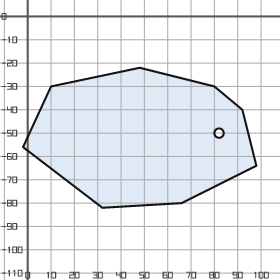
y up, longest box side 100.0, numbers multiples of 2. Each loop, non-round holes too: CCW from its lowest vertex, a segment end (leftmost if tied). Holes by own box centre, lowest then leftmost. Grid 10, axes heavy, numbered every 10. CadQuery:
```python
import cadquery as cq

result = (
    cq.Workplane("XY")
    .moveTo(32.0, -82.0)
    .lineTo(66.0, -80.0)
    .lineTo(98.0, -64.0)
    .lineTo(92.0, -40.0)
    .lineTo(80.0, -30.0)
    .lineTo(48.0, -22.0)
    .lineTo(10.0, -30.0)
    .lineTo(-2.0, -56.0)
    .close()
    .moveTo(82.0, -50.0)
    .circle(2.0)
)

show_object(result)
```